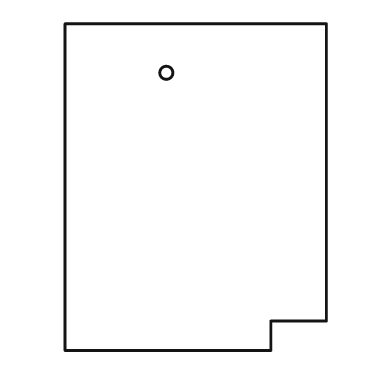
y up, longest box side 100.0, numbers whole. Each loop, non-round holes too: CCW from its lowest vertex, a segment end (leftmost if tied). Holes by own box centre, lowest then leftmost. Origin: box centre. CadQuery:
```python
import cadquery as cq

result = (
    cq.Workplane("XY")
    .moveTo(-40.0, -50.0)
    .lineTo(23.0, -50.0)
    .lineTo(23.0, -41.0)
    .lineTo(40.0, -41.0)
    .lineTo(40.0, 50.0)
    .lineTo(-40.0, 50.0)
    .close()
    .moveTo(-9.0, 35.0)
    .circle(2.0)
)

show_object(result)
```